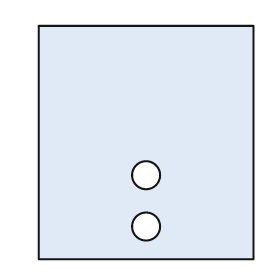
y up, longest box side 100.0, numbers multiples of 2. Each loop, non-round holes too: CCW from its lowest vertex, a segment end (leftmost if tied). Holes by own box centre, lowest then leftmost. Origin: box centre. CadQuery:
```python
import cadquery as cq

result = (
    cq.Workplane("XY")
    .moveTo(-46.0, -50.0)
    .lineTo(46.0, -50.0)
    .lineTo(46.0, 50.0)
    .lineTo(-46.0, 50.0)
    .close()
    .moveTo(0.0, -36.0)
    .circle(6.0)
    .moveTo(0.0, -14.0)
    .circle(6.0)
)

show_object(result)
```